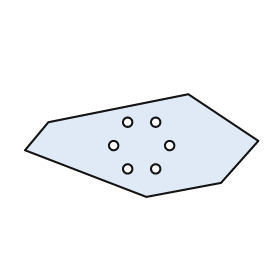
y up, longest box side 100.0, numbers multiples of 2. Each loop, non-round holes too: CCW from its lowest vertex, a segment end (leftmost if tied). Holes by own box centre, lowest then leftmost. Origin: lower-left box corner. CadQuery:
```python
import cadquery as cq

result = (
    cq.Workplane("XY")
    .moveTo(52.0, 0.0)
    .lineTo(84.0, 6.0)
    .lineTo(100.0, 24.0)
    .lineTo(70.0, 44.0)
    .lineTo(10.0, 32.0)
    .lineTo(0.0, 20.0)
    .close()
    .moveTo(44.0, 12.0)
    .circle(2.0)
    .moveTo(56.0, 12.0)
    .circle(2.0)
    .moveTo(38.0, 22.0)
    .circle(2.0)
    .moveTo(62.0, 22.0)
    .circle(2.0)
    .moveTo(44.0, 32.0)
    .circle(2.0)
    .moveTo(56.0, 32.0)
    .circle(2.0)
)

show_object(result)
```